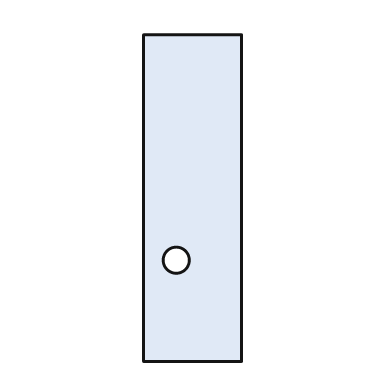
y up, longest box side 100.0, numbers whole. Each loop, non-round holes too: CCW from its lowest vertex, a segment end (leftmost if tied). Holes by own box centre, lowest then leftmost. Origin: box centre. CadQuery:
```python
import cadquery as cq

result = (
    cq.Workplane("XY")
    .moveTo(-15.0, -50.0)
    .lineTo(15.0, -50.0)
    .lineTo(15.0, 50.0)
    .lineTo(-15.0, 50.0)
    .close()
    .moveTo(-5.0, -19.0)
    .circle(4.0)
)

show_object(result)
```